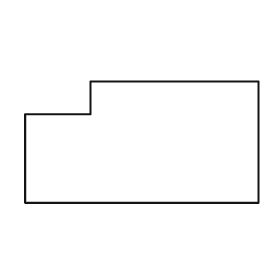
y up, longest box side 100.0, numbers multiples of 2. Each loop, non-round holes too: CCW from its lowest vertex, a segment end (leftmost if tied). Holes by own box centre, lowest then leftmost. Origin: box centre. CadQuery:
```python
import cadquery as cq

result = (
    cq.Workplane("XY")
    .moveTo(-50.0, -26.0)
    .lineTo(50.0, -26.0)
    .lineTo(50.0, 26.0)
    .lineTo(-22.0, 26.0)
    .lineTo(-22.0, 12.0)
    .lineTo(-50.0, 12.0)
    .close()
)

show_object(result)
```